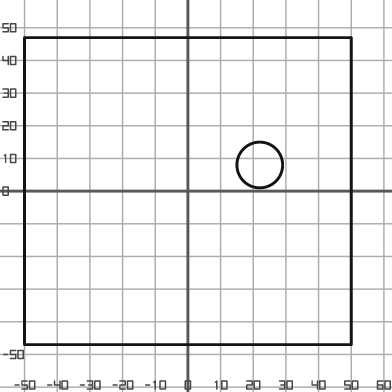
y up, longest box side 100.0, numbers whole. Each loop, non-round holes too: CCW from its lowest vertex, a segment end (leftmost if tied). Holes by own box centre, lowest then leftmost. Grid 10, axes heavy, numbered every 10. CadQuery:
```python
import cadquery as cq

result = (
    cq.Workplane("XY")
    .moveTo(-50.0, -47.0)
    .lineTo(50.0, -47.0)
    .lineTo(50.0, 47.0)
    .lineTo(-50.0, 47.0)
    .close()
    .moveTo(22.0, 8.0)
    .circle(7.0)
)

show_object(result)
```